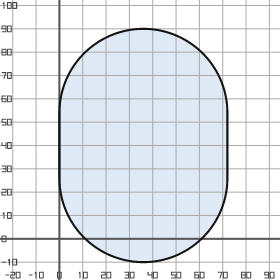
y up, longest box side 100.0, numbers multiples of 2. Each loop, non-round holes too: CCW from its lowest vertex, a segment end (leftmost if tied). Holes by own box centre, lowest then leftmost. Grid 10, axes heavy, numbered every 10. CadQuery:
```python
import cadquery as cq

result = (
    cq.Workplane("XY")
    .moveTo(0.0, 26.0)
    .threePointArc((36.0, -10.0), (72.0, 26.0))
    .lineTo(72.0, 54.0)
    .threePointArc((36.0, 90.0), (0.0, 54.0))
    .close()
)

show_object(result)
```